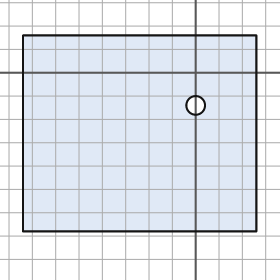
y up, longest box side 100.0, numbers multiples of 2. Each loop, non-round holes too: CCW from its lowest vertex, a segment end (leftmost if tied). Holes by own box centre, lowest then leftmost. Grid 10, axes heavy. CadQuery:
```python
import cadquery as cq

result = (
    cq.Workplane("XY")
    .moveTo(-74.0, -68.0)
    .lineTo(26.0, -68.0)
    .lineTo(26.0, 16.0)
    .lineTo(-74.0, 16.0)
    .close()
    .moveTo(0.0, -14.0)
    .circle(4.0)
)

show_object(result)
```